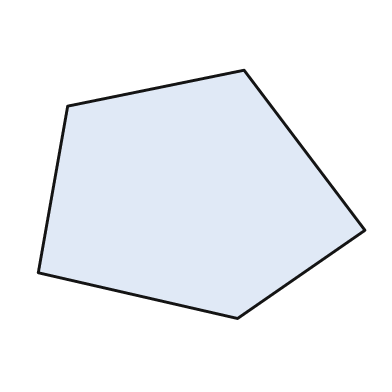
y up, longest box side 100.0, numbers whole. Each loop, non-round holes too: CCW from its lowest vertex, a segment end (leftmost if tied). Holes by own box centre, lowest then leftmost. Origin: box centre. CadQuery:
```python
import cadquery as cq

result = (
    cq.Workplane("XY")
    .moveTo(11.0, -38.0)
    .lineTo(50.0, -11.0)
    .lineTo(13.0, 38.0)
    .lineTo(-41.0, 27.0)
    .lineTo(-50.0, -24.0)
    .close()
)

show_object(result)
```